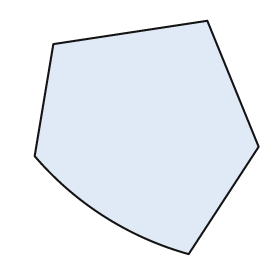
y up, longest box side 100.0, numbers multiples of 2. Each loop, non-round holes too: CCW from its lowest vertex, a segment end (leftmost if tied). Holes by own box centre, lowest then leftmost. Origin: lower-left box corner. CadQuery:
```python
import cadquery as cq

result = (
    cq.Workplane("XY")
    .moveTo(66.0, 0.0)
    .lineTo(96.0, 46.0)
    .lineTo(74.0, 100.0)
    .lineTo(8.0, 90.0)
    .lineTo(0.0, 42.0)
    .threePointArc((30.0, 16.0), (66.0, 0.0))
    .close()
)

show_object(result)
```